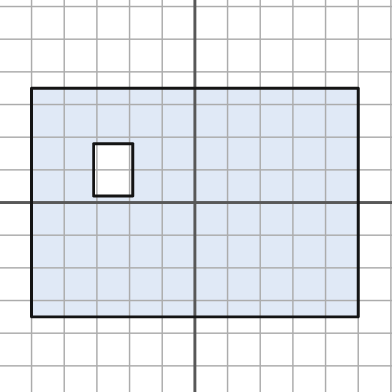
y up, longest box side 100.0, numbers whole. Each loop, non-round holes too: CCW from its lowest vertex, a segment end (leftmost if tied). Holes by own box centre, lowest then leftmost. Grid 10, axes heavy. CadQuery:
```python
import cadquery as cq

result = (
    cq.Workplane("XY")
    .moveTo(-50.0, -35.0)
    .lineTo(50.0, -35.0)
    .lineTo(50.0, 35.0)
    .lineTo(-50.0, 35.0)
    .close()
    .moveTo(-31.0, 2.0)
    .lineTo(-19.0, 2.0)
    .lineTo(-19.0, 18.0)
    .lineTo(-31.0, 18.0)
    .close()
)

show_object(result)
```